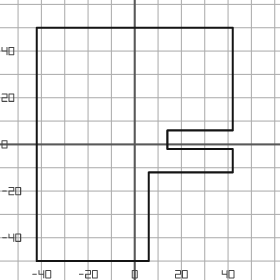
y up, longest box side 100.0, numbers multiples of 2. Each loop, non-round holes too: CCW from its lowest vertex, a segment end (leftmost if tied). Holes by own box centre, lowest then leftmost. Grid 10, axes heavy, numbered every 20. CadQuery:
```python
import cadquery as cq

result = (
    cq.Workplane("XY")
    .moveTo(-42.0, -50.0)
    .lineTo(6.0, -50.0)
    .lineTo(6.0, -12.0)
    .lineTo(42.0, -12.0)
    .lineTo(42.0, -2.0)
    .lineTo(14.0, -2.0)
    .lineTo(14.0, 6.0)
    .lineTo(42.0, 6.0)
    .lineTo(42.0, 50.0)
    .lineTo(-42.0, 50.0)
    .close()
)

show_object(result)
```